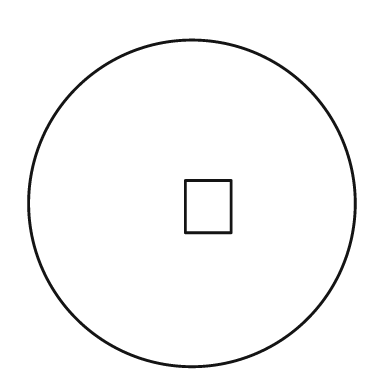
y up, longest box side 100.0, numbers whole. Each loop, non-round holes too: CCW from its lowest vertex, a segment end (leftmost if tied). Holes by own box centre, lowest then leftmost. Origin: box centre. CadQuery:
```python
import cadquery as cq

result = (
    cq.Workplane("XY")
    .moveTo(0.0, 0.0)
    .circle(50.0)
    .moveTo(-2.0, -9.0)
    .lineTo(12.0, -9.0)
    .lineTo(12.0, 7.0)
    .lineTo(-2.0, 7.0)
    .close()
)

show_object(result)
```